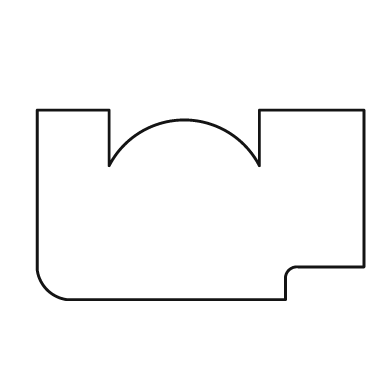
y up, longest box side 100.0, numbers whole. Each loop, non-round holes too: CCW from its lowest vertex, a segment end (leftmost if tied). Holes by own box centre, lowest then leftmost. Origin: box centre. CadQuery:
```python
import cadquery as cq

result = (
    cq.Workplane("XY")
    .moveTo(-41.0, -29.0)
    .lineTo(26.0, -29.0)
    .lineTo(26.0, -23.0)
    .threePointArc((27.0, -20.0), (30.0, -19.0))
    .lineTo(50.0, -19.0)
    .lineTo(50.0, 29.0)
    .lineTo(18.0, 29.0)
    .lineTo(18.0, 12.0)
    .threePointArc((-5.0, 26.0), (-28.0, 12.0))
    .lineTo(-28.0, 29.0)
    .lineTo(-50.0, 29.0)
    .lineTo(-50.0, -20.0)
    .threePointArc((-47.0, -26.0), (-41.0, -29.0))
    .close()
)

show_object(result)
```